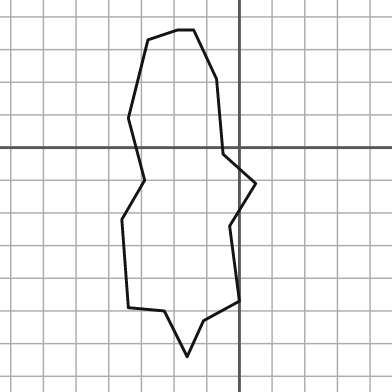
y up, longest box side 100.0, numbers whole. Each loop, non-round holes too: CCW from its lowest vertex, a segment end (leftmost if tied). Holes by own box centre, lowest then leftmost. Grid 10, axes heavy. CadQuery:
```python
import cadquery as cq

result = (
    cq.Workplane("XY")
    .moveTo(-16.0, -64.0)
    .lineTo(-11.0, -53.0)
    .lineTo(0.0, -47.0)
    .lineTo(-3.0, -24.0)
    .lineTo(5.0, -11.0)
    .lineTo(-5.0, -2.0)
    .lineTo(-7.0, 21.0)
    .lineTo(-14.0, 36.0)
    .lineTo(-19.0, 36.0)
    .lineTo(-28.0, 33.0)
    .lineTo(-34.0, 9.0)
    .lineTo(-29.0, -10.0)
    .lineTo(-36.0, -22.0)
    .lineTo(-34.0, -49.0)
    .lineTo(-23.0, -50.0)
    .close()
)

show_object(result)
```